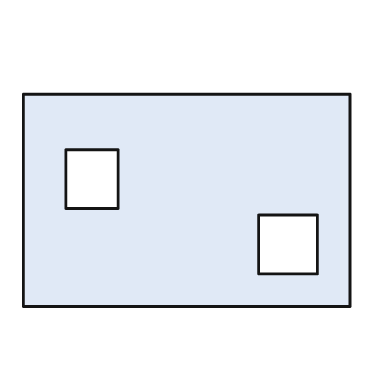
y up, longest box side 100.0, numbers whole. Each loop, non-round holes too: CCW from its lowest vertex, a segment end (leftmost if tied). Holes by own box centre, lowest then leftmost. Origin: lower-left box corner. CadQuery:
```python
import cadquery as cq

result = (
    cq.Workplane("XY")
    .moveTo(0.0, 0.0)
    .lineTo(100.0, 0.0)
    .lineTo(100.0, 65.0)
    .lineTo(0.0, 65.0)
    .close()
    .moveTo(72.0, 10.0)
    .lineTo(90.0, 10.0)
    .lineTo(90.0, 28.0)
    .lineTo(72.0, 28.0)
    .close()
    .moveTo(13.0, 30.0)
    .lineTo(29.0, 30.0)
    .lineTo(29.0, 48.0)
    .lineTo(13.0, 48.0)
    .close()
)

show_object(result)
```